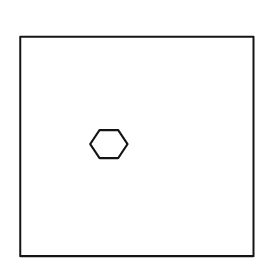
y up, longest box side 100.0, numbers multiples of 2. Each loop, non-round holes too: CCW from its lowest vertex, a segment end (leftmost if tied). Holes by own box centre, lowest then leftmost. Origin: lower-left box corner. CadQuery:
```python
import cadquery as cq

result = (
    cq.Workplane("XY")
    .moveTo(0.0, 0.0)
    .lineTo(100.0, 0.0)
    .lineTo(100.0, 94.0)
    .lineTo(0.0, 94.0)
    .close()
    .moveTo(34.0, 42.0)
    .lineTo(42.0, 42.0)
    .lineTo(46.0, 48.0)
    .lineTo(42.0, 54.0)
    .lineTo(34.0, 54.0)
    .lineTo(30.0, 48.0)
    .close()
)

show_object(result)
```